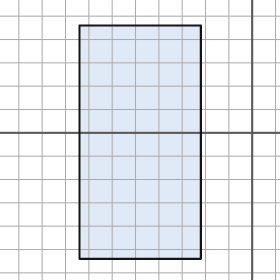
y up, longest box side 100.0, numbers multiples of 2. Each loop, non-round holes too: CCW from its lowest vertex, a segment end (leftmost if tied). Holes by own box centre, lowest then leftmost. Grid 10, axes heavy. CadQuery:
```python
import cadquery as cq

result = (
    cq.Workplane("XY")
    .moveTo(-74.0, -54.0)
    .lineTo(-22.0, -54.0)
    .lineTo(-22.0, 46.0)
    .lineTo(-74.0, 46.0)
    .close()
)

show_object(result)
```